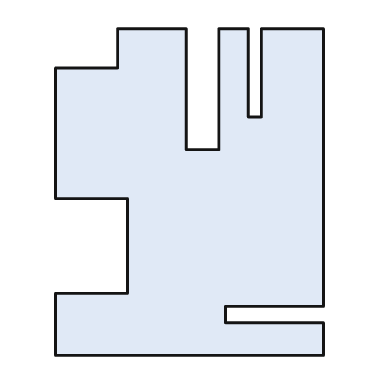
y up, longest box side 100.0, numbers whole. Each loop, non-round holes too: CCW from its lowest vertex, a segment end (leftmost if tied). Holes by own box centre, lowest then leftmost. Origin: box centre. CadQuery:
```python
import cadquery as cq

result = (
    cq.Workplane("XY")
    .moveTo(-41.0, -50.0)
    .lineTo(41.0, -50.0)
    .lineTo(41.0, -40.0)
    .lineTo(11.0, -40.0)
    .lineTo(11.0, -35.0)
    .lineTo(41.0, -35.0)
    .lineTo(41.0, 50.0)
    .lineTo(22.0, 50.0)
    .lineTo(22.0, 23.0)
    .lineTo(18.0, 23.0)
    .lineTo(18.0, 50.0)
    .lineTo(9.0, 50.0)
    .lineTo(9.0, 13.0)
    .lineTo(-1.0, 13.0)
    .lineTo(-1.0, 50.0)
    .lineTo(-22.0, 50.0)
    .lineTo(-22.0, 38.0)
    .lineTo(-41.0, 38.0)
    .lineTo(-41.0, -2.0)
    .lineTo(-19.0, -2.0)
    .lineTo(-19.0, -31.0)
    .lineTo(-41.0, -31.0)
    .close()
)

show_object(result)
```